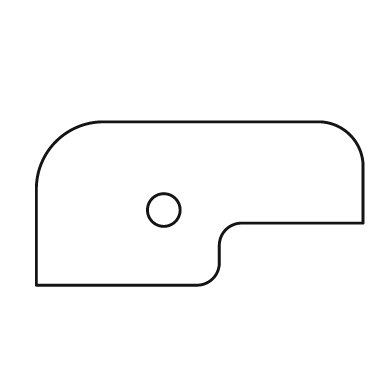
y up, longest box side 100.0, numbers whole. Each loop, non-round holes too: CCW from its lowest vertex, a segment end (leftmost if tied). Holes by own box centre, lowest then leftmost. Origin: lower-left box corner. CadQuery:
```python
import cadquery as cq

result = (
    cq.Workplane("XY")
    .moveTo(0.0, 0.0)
    .lineTo(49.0, 0.0)
    .threePointArc((54.0, 2.0), (56.0, 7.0))
    .lineTo(56.0, 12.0)
    .threePointArc((58.0, 17.0), (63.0, 19.0))
    .lineTo(100.0, 19.0)
    .lineTo(100.0, 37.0)
    .threePointArc((96.0, 46.0), (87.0, 50.0))
    .lineTo(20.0, 50.0)
    .threePointArc((6.0, 44.0), (0.0, 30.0))
    .close()
    .moveTo(39.0, 23.0)
    .circle(5.0)
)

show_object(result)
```